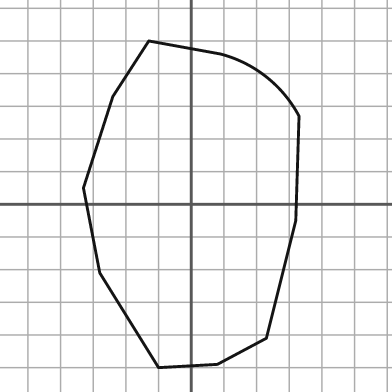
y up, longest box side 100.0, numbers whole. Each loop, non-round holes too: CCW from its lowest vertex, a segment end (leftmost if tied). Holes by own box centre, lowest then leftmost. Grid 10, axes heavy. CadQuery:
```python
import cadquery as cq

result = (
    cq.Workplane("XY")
    .moveTo(-10.0, -50.0)
    .lineTo(8.0, -49.0)
    .lineTo(23.0, -41.0)
    .lineTo(32.0, -5.0)
    .lineTo(33.0, 27.0)
    .threePointArc((23.0, 39.0), (9.0, 46.0))
    .lineTo(-13.0, 50.0)
    .lineTo(-24.0, 33.0)
    .lineTo(-33.0, 5.0)
    .lineTo(-28.0, -21.0)
    .close()
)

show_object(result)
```